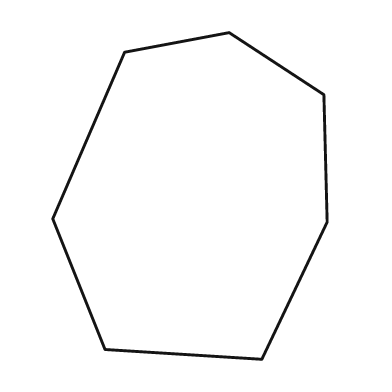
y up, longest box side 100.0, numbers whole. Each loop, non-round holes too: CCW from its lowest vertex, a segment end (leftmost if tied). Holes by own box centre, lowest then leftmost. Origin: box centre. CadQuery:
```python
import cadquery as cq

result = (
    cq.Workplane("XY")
    .moveTo(22.0, -50.0)
    .lineTo(42.0, -8.0)
    .lineTo(41.0, 31.0)
    .lineTo(12.0, 50.0)
    .lineTo(-20.0, 44.0)
    .lineTo(-42.0, -7.0)
    .lineTo(-26.0, -47.0)
    .close()
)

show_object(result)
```